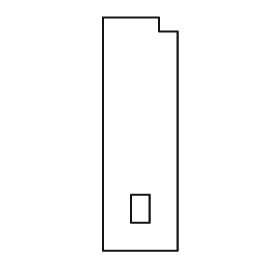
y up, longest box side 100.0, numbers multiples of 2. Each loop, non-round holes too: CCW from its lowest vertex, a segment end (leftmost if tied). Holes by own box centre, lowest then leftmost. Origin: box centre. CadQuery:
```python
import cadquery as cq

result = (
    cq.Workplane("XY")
    .moveTo(-16.0, -50.0)
    .lineTo(16.0, -50.0)
    .lineTo(16.0, 44.0)
    .lineTo(8.0, 44.0)
    .lineTo(8.0, 50.0)
    .lineTo(-16.0, 50.0)
    .close()
    .moveTo(-4.0, -38.0)
    .lineTo(4.0, -38.0)
    .lineTo(4.0, -26.0)
    .lineTo(-4.0, -26.0)
    .close()
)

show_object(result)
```